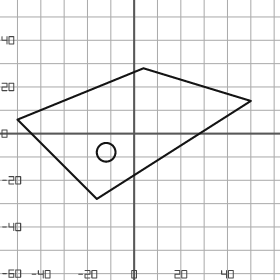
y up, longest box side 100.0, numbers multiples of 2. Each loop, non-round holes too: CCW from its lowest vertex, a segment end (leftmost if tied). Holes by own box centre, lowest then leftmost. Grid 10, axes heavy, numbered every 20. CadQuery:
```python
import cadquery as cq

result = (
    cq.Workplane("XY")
    .moveTo(-16.0, -28.0)
    .lineTo(50.0, 14.0)
    .lineTo(4.0, 28.0)
    .lineTo(-50.0, 6.0)
    .close()
    .moveTo(-12.0, -8.0)
    .circle(4.0)
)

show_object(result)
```